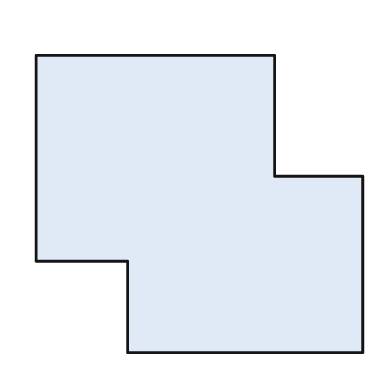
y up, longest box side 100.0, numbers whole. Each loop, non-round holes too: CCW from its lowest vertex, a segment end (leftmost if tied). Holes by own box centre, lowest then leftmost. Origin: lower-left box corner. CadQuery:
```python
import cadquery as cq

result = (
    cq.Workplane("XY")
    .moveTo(28.0, 0.0)
    .lineTo(100.0, 0.0)
    .lineTo(100.0, 54.0)
    .lineTo(73.0, 54.0)
    .lineTo(73.0, 91.0)
    .lineTo(0.0, 91.0)
    .lineTo(0.0, 28.0)
    .lineTo(28.0, 28.0)
    .close()
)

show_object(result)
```